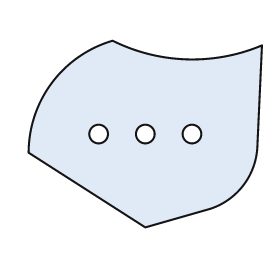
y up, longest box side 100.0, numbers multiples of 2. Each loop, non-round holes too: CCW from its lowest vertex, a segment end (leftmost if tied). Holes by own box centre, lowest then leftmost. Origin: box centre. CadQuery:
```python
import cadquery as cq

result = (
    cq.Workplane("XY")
    .moveTo(0.0, -40.0)
    .lineTo(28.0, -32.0)
    .threePointArc((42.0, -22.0), (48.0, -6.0))
    .lineTo(50.0, 38.0)
    .threePointArc((18.0, 32.0), (-14.0, 40.0))
    .threePointArc((-40.0, 22.0), (-50.0, -8.0))
    .close()
    .moveTo(-20.0, 0.0)
    .circle(4.0)
    .moveTo(0.0, 0.0)
    .circle(4.0)
    .moveTo(20.0, 0.0)
    .circle(4.0)
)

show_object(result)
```